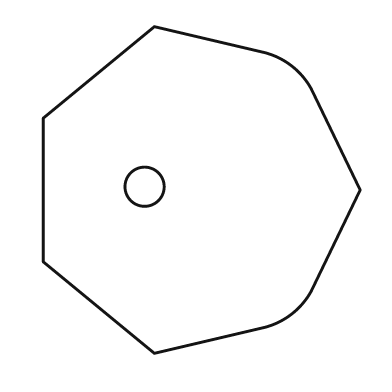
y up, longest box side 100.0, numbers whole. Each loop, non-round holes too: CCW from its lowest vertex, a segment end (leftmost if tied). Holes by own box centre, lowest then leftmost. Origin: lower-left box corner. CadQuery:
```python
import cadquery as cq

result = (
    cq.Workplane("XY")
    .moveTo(34.0, 0.0)
    .lineTo(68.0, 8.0)
    .threePointArc((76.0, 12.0), (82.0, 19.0))
    .lineTo(97.0, 50.0)
    .lineTo(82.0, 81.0)
    .threePointArc((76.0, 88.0), (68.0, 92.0))
    .lineTo(34.0, 100.0)
    .lineTo(0.0, 72.0)
    .lineTo(0.0, 28.0)
    .close()
    .moveTo(31.0, 51.0)
    .circle(6.0)
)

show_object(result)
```